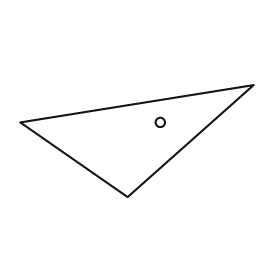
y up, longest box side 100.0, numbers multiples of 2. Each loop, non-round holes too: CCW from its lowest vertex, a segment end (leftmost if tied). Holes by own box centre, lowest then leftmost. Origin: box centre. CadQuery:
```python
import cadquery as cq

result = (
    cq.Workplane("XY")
    .moveTo(-4.0, -24.0)
    .lineTo(50.0, 24.0)
    .lineTo(-50.0, 8.0)
    .close()
    .moveTo(10.0, 8.0)
    .circle(2.0)
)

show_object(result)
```